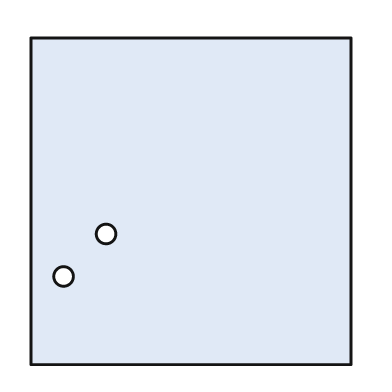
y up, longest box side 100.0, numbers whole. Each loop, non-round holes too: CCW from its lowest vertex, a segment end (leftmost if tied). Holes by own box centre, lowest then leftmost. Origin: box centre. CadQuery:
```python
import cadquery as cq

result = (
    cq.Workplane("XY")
    .moveTo(-49.0, -50.0)
    .lineTo(49.0, -50.0)
    .lineTo(49.0, 50.0)
    .lineTo(-49.0, 50.0)
    .close()
    .moveTo(-39.0, -23.0)
    .circle(3.0)
    .moveTo(-26.0, -10.0)
    .circle(3.0)
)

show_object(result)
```